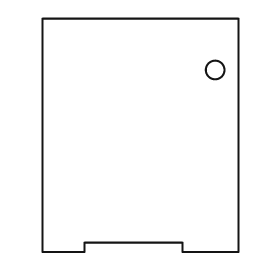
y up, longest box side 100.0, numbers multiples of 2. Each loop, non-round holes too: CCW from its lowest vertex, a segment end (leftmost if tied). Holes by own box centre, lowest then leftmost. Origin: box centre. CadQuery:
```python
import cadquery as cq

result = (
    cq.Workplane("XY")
    .moveTo(-42.0, -50.0)
    .lineTo(-24.0, -50.0)
    .lineTo(-24.0, -46.0)
    .lineTo(18.0, -46.0)
    .lineTo(18.0, -50.0)
    .lineTo(42.0, -50.0)
    .lineTo(42.0, 50.0)
    .lineTo(-42.0, 50.0)
    .close()
    .moveTo(32.0, 28.0)
    .circle(4.0)
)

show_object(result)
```